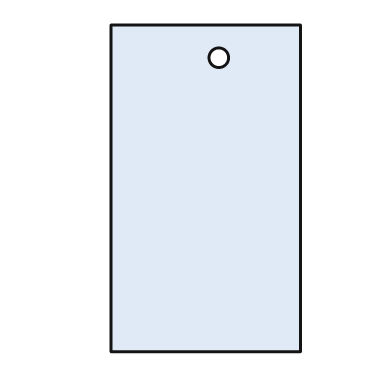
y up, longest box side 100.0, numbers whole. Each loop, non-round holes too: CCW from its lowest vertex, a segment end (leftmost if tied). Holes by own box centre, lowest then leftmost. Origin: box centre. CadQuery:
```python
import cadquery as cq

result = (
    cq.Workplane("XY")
    .moveTo(-29.0, -50.0)
    .lineTo(29.0, -50.0)
    .lineTo(29.0, 50.0)
    .lineTo(-29.0, 50.0)
    .close()
    .moveTo(4.0, 40.0)
    .circle(3.0)
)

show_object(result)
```